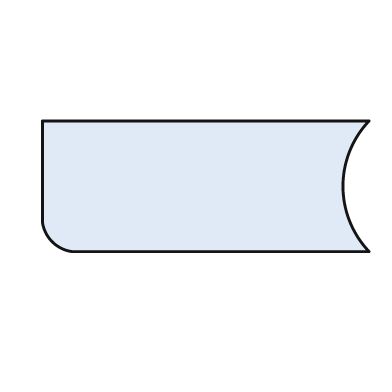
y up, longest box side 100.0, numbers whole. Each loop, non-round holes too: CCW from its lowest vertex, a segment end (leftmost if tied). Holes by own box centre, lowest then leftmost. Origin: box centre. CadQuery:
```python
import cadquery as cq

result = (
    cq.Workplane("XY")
    .moveTo(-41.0, -20.0)
    .lineTo(50.0, -20.0)
    .threePointArc((42.0, 0.0), (50.0, 20.0))
    .lineTo(-50.0, 20.0)
    .lineTo(-50.0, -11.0)
    .threePointArc((-47.0, -17.0), (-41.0, -20.0))
    .close()
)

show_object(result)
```